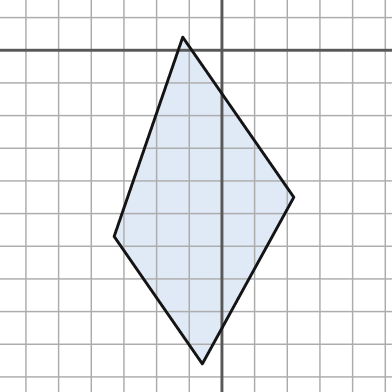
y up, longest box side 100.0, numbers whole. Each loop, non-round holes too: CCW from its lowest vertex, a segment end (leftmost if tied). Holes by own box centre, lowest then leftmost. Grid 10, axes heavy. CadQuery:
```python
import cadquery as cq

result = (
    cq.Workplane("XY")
    .moveTo(-6.0, -96.0)
    .lineTo(22.0, -45.0)
    .lineTo(-12.0, 4.0)
    .lineTo(-33.0, -57.0)
    .close()
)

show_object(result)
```